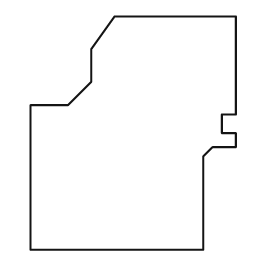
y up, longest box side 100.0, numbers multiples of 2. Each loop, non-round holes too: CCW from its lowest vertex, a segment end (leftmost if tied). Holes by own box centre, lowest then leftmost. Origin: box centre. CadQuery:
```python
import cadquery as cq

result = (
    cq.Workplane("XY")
    .moveTo(-44.0, -50.0)
    .lineTo(30.0, -50.0)
    .lineTo(30.0, -10.0)
    .lineTo(34.0, -6.0)
    .lineTo(44.0, -6.0)
    .lineTo(44.0, 0.0)
    .lineTo(38.0, 0.0)
    .lineTo(38.0, 8.0)
    .lineTo(44.0, 8.0)
    .lineTo(44.0, 50.0)
    .lineTo(-8.0, 50.0)
    .lineTo(-18.0, 36.0)
    .lineTo(-18.0, 22.0)
    .lineTo(-28.0, 12.0)
    .lineTo(-44.0, 12.0)
    .close()
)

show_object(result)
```